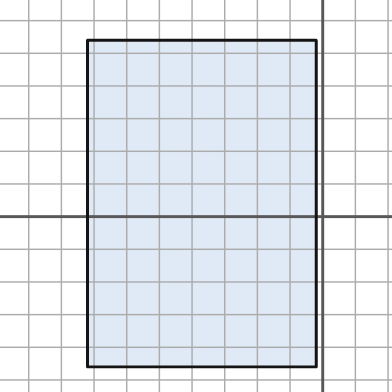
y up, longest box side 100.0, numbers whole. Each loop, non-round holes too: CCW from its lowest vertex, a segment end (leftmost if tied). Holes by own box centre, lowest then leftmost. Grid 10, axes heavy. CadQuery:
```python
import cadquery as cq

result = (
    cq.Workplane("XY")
    .moveTo(-72.0, -46.0)
    .lineTo(-2.0, -46.0)
    .lineTo(-2.0, 54.0)
    .lineTo(-72.0, 54.0)
    .close()
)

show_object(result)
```